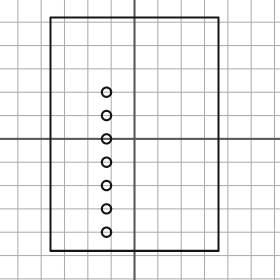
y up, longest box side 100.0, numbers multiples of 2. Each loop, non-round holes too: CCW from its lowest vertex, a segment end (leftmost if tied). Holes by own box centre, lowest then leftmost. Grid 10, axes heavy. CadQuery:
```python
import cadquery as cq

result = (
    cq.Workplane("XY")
    .moveTo(-36.0, -48.0)
    .lineTo(36.0, -48.0)
    .lineTo(36.0, 52.0)
    .lineTo(-36.0, 52.0)
    .close()
    .moveTo(-12.0, -40.0)
    .circle(2.0)
    .moveTo(-12.0, -30.0)
    .circle(2.0)
    .moveTo(-12.0, -20.0)
    .circle(2.0)
    .moveTo(-12.0, -10.0)
    .circle(2.0)
    .moveTo(-12.0, 0.0)
    .circle(2.0)
    .moveTo(-12.0, 10.0)
    .circle(2.0)
    .moveTo(-12.0, 20.0)
    .circle(2.0)
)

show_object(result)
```